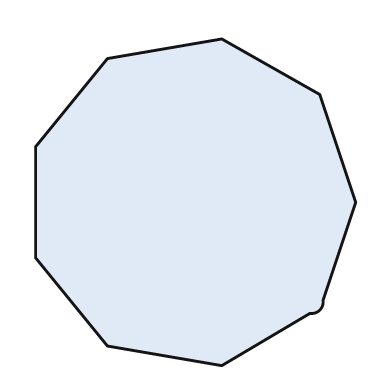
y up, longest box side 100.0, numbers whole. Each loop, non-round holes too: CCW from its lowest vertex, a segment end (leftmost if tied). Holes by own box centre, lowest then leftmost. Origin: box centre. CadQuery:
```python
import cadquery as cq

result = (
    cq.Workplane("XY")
    .moveTo(8.0, -50.0)
    .lineTo(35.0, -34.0)
    .threePointArc((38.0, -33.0), (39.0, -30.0))
    .lineTo(49.0, 0.0)
    .lineTo(38.0, 33.0)
    .lineTo(8.0, 50.0)
    .lineTo(-27.0, 44.0)
    .lineTo(-49.0, 17.0)
    .lineTo(-49.0, -17.0)
    .lineTo(-27.0, -44.0)
    .close()
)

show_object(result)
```